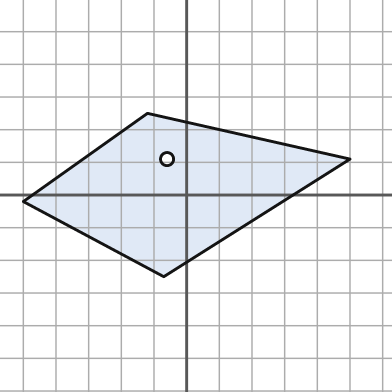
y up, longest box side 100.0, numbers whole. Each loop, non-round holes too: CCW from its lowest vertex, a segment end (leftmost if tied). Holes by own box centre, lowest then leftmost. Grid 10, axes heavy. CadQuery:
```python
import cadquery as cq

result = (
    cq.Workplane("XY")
    .moveTo(-7.0, -25.0)
    .lineTo(50.0, 11.0)
    .lineTo(-12.0, 25.0)
    .lineTo(-50.0, -2.0)
    .close()
    .moveTo(-6.0, 11.0)
    .circle(2.0)
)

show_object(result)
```